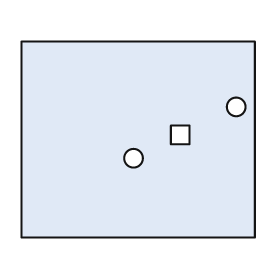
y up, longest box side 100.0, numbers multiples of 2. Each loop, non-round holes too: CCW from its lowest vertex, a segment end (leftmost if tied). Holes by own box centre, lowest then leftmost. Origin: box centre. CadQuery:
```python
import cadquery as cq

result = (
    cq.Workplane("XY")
    .moveTo(-50.0, -42.0)
    .lineTo(50.0, -42.0)
    .lineTo(50.0, 42.0)
    .lineTo(-50.0, 42.0)
    .close()
    .moveTo(-2.0, -8.0)
    .circle(4.0)
    .moveTo(14.0, -2.0)
    .lineTo(22.0, -2.0)
    .lineTo(22.0, 6.0)
    .lineTo(14.0, 6.0)
    .close()
    .moveTo(42.0, 14.0)
    .circle(4.0)
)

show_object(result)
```